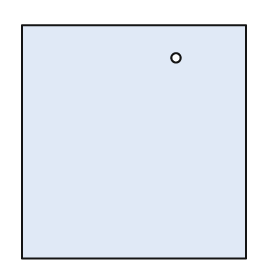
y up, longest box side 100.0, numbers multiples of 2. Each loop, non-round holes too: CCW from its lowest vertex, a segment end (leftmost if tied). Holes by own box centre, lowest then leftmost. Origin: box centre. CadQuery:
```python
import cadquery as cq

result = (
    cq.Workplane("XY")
    .moveTo(-48.0, -50.0)
    .lineTo(48.0, -50.0)
    .lineTo(48.0, 50.0)
    .lineTo(-48.0, 50.0)
    .close()
    .moveTo(18.0, 36.0)
    .circle(2.0)
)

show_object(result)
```